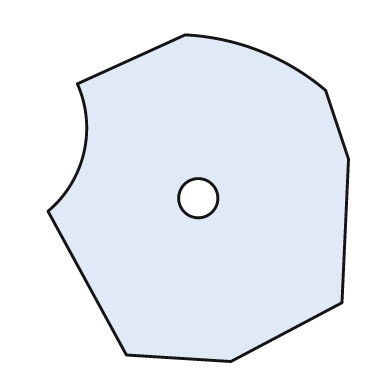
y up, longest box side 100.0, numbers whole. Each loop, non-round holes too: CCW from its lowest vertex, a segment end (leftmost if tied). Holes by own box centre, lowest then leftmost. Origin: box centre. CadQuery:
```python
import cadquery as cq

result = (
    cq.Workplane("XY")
    .moveTo(10.0, -50.0)
    .lineTo(44.0, -32.0)
    .lineTo(46.0, 12.0)
    .lineTo(39.0, 33.0)
    .threePointArc((19.0, 45.0), (-4.0, 50.0))
    .lineTo(-37.0, 35.0)
    .threePointArc((-35.0, 14.0), (-46.0, -4.0))
    .lineTo(-22.0, -48.0)
    .close()
    .moveTo(0.0, 0.0)
    .circle(6.0)
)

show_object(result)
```